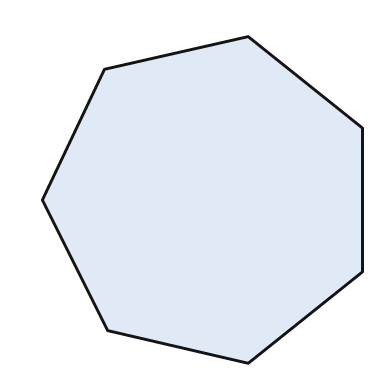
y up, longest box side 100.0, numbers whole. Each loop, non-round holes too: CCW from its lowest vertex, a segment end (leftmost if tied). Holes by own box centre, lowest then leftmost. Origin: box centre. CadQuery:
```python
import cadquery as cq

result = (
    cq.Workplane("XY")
    .moveTo(14.0, -50.0)
    .lineTo(49.0, -22.0)
    .lineTo(49.0, 22.0)
    .lineTo(14.0, 50.0)
    .lineTo(-30.0, 40.0)
    .lineTo(-49.0, 0.0)
    .lineTo(-29.0, -40.0)
    .close()
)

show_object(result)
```